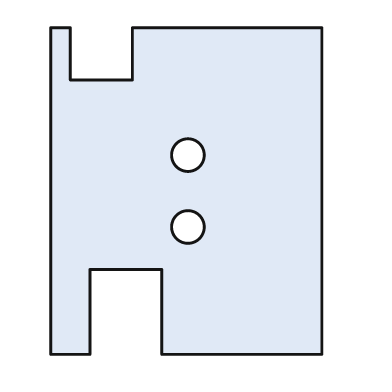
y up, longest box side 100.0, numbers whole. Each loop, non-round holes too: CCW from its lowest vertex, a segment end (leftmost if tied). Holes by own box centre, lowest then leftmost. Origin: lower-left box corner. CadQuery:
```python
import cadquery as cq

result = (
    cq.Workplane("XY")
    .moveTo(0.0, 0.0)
    .lineTo(12.0, 0.0)
    .lineTo(12.0, 26.0)
    .lineTo(34.0, 26.0)
    .lineTo(34.0, 0.0)
    .lineTo(83.0, 0.0)
    .lineTo(83.0, 100.0)
    .lineTo(25.0, 100.0)
    .lineTo(25.0, 84.0)
    .lineTo(6.0, 84.0)
    .lineTo(6.0, 100.0)
    .lineTo(0.0, 100.0)
    .close()
    .moveTo(42.0, 39.0)
    .circle(5.0)
    .moveTo(42.0, 61.0)
    .circle(5.0)
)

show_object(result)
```